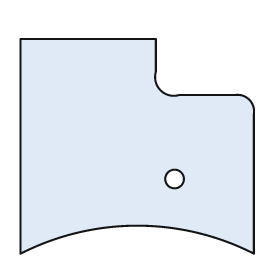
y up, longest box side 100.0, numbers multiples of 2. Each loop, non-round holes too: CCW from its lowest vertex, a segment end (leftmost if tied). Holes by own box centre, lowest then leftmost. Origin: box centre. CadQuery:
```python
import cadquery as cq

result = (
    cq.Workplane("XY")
    .moveTo(-50.0, -46.0)
    .threePointArc((0.0, -34.0), (50.0, -46.0))
    .lineTo(50.0, 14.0)
    .threePointArc((48.0, 20.0), (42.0, 22.0))
    .lineTo(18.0, 22.0)
    .threePointArc((10.0, 24.0), (8.0, 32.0))
    .lineTo(8.0, 46.0)
    .lineTo(-50.0, 46.0)
    .close()
    .moveTo(16.0, -14.0)
    .circle(4.0)
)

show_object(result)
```